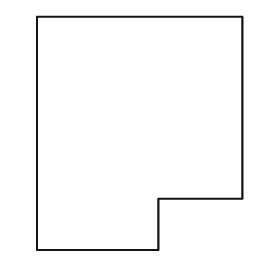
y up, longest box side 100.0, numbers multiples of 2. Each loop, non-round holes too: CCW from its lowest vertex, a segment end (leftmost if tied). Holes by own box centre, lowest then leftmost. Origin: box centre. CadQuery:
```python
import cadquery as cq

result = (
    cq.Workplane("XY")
    .moveTo(-44.0, -50.0)
    .lineTo(8.0, -50.0)
    .lineTo(8.0, -28.0)
    .lineTo(44.0, -28.0)
    .lineTo(44.0, 50.0)
    .lineTo(-44.0, 50.0)
    .close()
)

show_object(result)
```